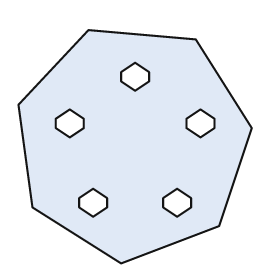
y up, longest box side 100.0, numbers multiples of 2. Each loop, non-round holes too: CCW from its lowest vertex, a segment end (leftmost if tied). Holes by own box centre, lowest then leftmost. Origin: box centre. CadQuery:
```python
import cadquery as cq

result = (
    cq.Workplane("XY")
    .moveTo(-6.0, -50.0)
    .lineTo(36.0, -34.0)
    .lineTo(50.0, 8.0)
    .lineTo(26.0, 46.0)
    .lineTo(-20.0, 50.0)
    .lineTo(-50.0, 18.0)
    .lineTo(-44.0, -26.0)
    .close()
    .moveTo(-18.0, -30.0)
    .lineTo(-12.0, -26.0)
    .lineTo(-12.0, -22.0)
    .lineTo(-18.0, -18.0)
    .lineTo(-24.0, -22.0)
    .lineTo(-24.0, -26.0)
    .close()
    .moveTo(18.0, -30.0)
    .lineTo(24.0, -26.0)
    .lineTo(24.0, -22.0)
    .lineTo(18.0, -18.0)
    .lineTo(12.0, -22.0)
    .lineTo(12.0, -26.0)
    .close()
    .moveTo(-28.0, 4.0)
    .lineTo(-22.0, 8.0)
    .lineTo(-22.0, 12.0)
    .lineTo(-28.0, 16.0)
    .lineTo(-34.0, 12.0)
    .lineTo(-34.0, 8.0)
    .close()
    .moveTo(28.0, 4.0)
    .lineTo(34.0, 8.0)
    .lineTo(34.0, 12.0)
    .lineTo(28.0, 16.0)
    .lineTo(22.0, 12.0)
    .lineTo(22.0, 8.0)
    .close()
    .moveTo(0.0, 24.0)
    .lineTo(6.0, 28.0)
    .lineTo(6.0, 32.0)
    .lineTo(0.0, 36.0)
    .lineTo(-6.0, 32.0)
    .lineTo(-6.0, 28.0)
    .close()
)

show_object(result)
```